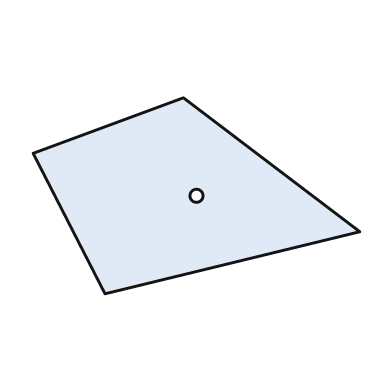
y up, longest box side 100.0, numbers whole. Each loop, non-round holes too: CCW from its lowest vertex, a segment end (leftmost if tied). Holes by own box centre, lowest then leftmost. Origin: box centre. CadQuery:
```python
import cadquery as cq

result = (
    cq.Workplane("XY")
    .moveTo(-28.0, -30.0)
    .lineTo(50.0, -11.0)
    .lineTo(-4.0, 30.0)
    .lineTo(-50.0, 13.0)
    .close()
    .moveTo(0.0, 0.0)
    .circle(2.0)
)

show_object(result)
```